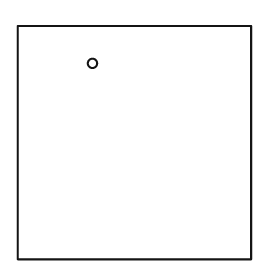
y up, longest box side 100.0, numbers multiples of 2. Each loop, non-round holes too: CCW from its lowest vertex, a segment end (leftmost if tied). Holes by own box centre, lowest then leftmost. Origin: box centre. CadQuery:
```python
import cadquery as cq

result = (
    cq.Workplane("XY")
    .moveTo(-50.0, -50.0)
    .lineTo(50.0, -50.0)
    .lineTo(50.0, 50.0)
    .lineTo(-50.0, 50.0)
    .close()
    .moveTo(-18.0, 34.0)
    .circle(2.0)
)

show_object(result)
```